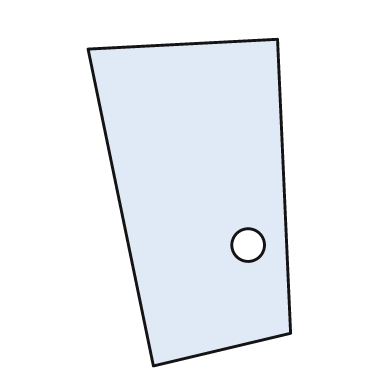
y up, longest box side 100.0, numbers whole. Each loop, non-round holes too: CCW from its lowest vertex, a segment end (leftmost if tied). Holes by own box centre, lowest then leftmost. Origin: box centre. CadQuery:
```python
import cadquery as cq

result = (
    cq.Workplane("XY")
    .moveTo(-11.0, -50.0)
    .lineTo(31.0, -40.0)
    .lineTo(27.0, 50.0)
    .lineTo(-31.0, 47.0)
    .close()
    .moveTo(18.0, -13.0)
    .circle(5.0)
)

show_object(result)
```